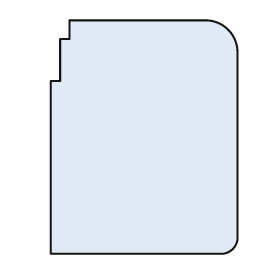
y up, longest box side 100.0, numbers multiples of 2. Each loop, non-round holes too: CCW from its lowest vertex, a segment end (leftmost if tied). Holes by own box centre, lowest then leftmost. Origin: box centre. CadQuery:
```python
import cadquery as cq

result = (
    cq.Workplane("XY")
    .moveTo(-40.0, -50.0)
    .lineTo(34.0, -50.0)
    .threePointArc((38.0, -48.0), (40.0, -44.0))
    .lineTo(40.0, 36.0)
    .threePointArc((36.0, 46.0), (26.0, 50.0))
    .lineTo(-32.0, 50.0)
    .lineTo(-32.0, 42.0)
    .lineTo(-36.0, 42.0)
    .lineTo(-36.0, 24.0)
    .lineTo(-40.0, 24.0)
    .close()
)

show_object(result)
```